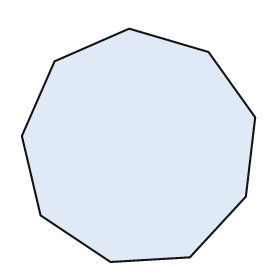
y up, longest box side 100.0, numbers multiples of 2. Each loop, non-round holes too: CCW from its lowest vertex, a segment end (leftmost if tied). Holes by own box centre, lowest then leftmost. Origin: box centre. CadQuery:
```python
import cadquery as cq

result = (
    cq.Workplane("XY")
    .moveTo(-12.0, -50.0)
    .lineTo(22.0, -48.0)
    .lineTo(46.0, -22.0)
    .lineTo(50.0, 12.0)
    .lineTo(30.0, 40.0)
    .lineTo(-4.0, 50.0)
    .lineTo(-36.0, 36.0)
    .lineTo(-50.0, 4.0)
    .lineTo(-42.0, -30.0)
    .close()
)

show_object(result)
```